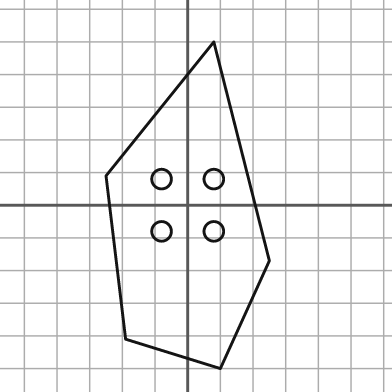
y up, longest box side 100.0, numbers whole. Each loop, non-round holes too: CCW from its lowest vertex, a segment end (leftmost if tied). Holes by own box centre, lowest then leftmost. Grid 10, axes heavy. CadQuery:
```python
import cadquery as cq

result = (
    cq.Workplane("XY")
    .moveTo(10.0, -50.0)
    .lineTo(25.0, -17.0)
    .lineTo(8.0, 50.0)
    .lineTo(-25.0, 9.0)
    .lineTo(-19.0, -41.0)
    .close()
    .moveTo(-8.0, -8.0)
    .circle(3.0)
    .moveTo(8.0, -8.0)
    .circle(3.0)
    .moveTo(-8.0, 8.0)
    .circle(3.0)
    .moveTo(8.0, 8.0)
    .circle(3.0)
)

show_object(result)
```